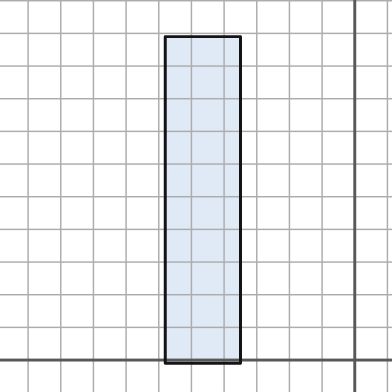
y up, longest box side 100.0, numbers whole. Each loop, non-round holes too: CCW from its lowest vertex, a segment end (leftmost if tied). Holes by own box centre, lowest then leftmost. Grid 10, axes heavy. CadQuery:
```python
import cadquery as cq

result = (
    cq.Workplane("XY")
    .moveTo(-58.0, -1.0)
    .lineTo(-35.0, -1.0)
    .lineTo(-35.0, 99.0)
    .lineTo(-58.0, 99.0)
    .close()
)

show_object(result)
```